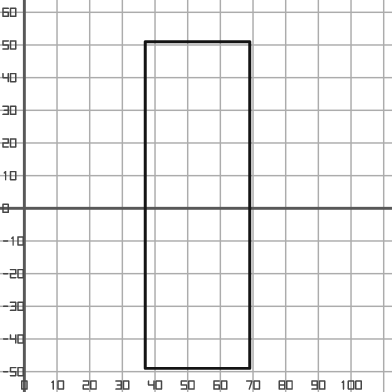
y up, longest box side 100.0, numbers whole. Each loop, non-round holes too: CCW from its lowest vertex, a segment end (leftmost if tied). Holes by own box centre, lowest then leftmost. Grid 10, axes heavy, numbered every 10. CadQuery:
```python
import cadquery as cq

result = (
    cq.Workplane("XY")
    .moveTo(37.0, -49.0)
    .lineTo(69.0, -49.0)
    .lineTo(69.0, 51.0)
    .lineTo(37.0, 51.0)
    .close()
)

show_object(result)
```